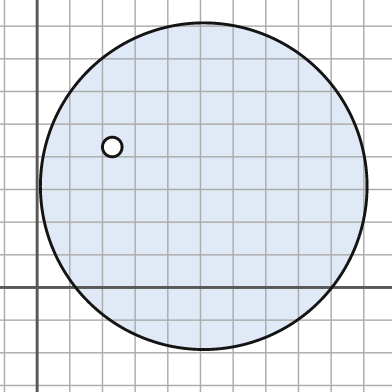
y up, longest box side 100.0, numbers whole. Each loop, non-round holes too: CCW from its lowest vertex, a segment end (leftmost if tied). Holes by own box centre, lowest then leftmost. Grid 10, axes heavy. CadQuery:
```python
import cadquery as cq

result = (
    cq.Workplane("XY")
    .moveTo(51.0, 31.0)
    .circle(50.0)
    .moveTo(23.0, 43.0)
    .circle(3.0)
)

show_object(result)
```